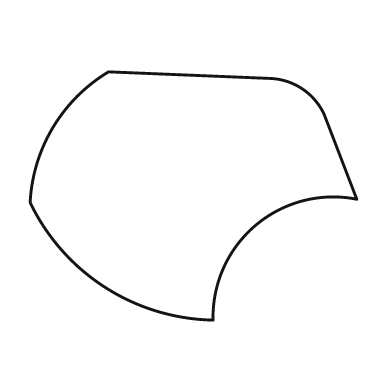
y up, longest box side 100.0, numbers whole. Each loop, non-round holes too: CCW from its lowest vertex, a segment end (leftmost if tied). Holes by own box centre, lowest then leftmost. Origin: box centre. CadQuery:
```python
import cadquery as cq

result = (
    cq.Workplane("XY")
    .moveTo(6.0, -38.0)
    .threePointArc((19.0, -9.0), (50.0, -1.0))
    .lineTo(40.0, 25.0)
    .threePointArc((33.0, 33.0), (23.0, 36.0))
    .lineTo(-26.0, 38.0)
    .threePointArc((-43.0, 21.0), (-50.0, -2.0))
    .threePointArc((-27.0, -28.0), (6.0, -38.0))
    .close()
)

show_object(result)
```